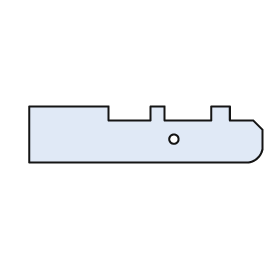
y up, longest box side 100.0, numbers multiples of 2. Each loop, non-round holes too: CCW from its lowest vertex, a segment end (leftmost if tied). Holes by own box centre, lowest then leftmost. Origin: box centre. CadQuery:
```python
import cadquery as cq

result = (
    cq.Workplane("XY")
    .moveTo(-50.0, -12.0)
    .lineTo(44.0, -12.0)
    .threePointArc((48.0, -10.0), (50.0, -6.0))
    .lineTo(50.0, 2.0)
    .lineTo(46.0, 6.0)
    .lineTo(36.0, 6.0)
    .lineTo(36.0, 12.0)
    .lineTo(28.0, 12.0)
    .lineTo(28.0, 6.0)
    .lineTo(8.0, 6.0)
    .lineTo(8.0, 12.0)
    .lineTo(2.0, 12.0)
    .lineTo(2.0, 6.0)
    .lineTo(-16.0, 6.0)
    .lineTo(-16.0, 12.0)
    .lineTo(-50.0, 12.0)
    .close()
    .moveTo(12.0, -2.0)
    .circle(2.0)
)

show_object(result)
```